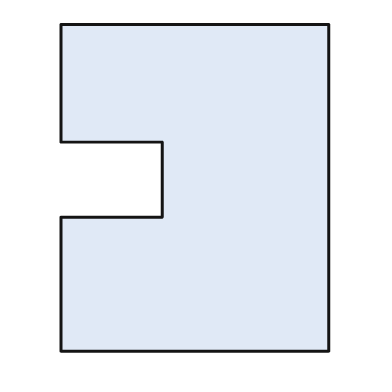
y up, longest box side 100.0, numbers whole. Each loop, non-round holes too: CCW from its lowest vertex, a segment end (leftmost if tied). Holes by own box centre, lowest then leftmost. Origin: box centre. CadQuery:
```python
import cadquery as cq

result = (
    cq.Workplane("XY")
    .moveTo(-41.0, -50.0)
    .lineTo(41.0, -50.0)
    .lineTo(41.0, 50.0)
    .lineTo(-41.0, 50.0)
    .lineTo(-41.0, 14.0)
    .lineTo(-10.0, 14.0)
    .lineTo(-10.0, -9.0)
    .lineTo(-41.0, -9.0)
    .close()
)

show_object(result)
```